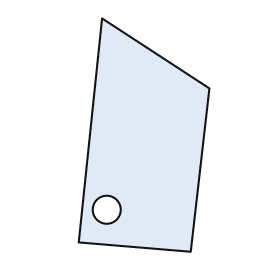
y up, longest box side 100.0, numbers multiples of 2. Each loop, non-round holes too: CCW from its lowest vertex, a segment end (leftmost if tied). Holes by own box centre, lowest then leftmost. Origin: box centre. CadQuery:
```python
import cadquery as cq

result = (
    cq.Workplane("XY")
    .moveTo(20.0, -50.0)
    .lineTo(28.0, 20.0)
    .lineTo(-18.0, 50.0)
    .lineTo(-28.0, -46.0)
    .close()
    .moveTo(-16.0, -32.0)
    .circle(6.0)
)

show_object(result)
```